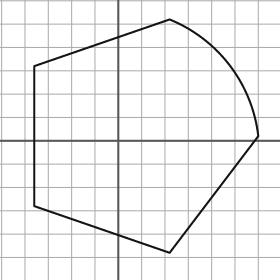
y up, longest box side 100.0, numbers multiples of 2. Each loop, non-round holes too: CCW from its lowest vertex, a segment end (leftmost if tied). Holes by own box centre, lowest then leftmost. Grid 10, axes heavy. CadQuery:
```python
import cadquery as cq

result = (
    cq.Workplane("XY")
    .moveTo(22.0, -48.0)
    .lineTo(60.0, 2.0)
    .threePointArc((48.0, 32.0), (22.0, 52.0))
    .lineTo(-36.0, 32.0)
    .lineTo(-36.0, -28.0)
    .close()
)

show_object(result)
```